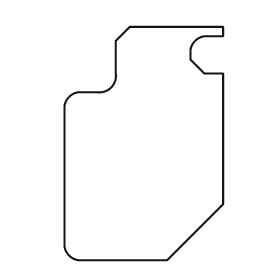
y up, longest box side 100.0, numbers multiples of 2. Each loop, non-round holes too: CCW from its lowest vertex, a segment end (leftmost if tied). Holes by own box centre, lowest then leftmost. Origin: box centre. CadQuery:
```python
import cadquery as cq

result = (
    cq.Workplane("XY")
    .moveTo(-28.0, -50.0)
    .lineTo(10.0, -50.0)
    .lineTo(34.0, -26.0)
    .lineTo(34.0, 30.0)
    .lineTo(26.0, 30.0)
    .lineTo(20.0, 36.0)
    .lineTo(20.0, 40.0)
    .threePointArc((22.0, 44.0), (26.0, 46.0))
    .lineTo(34.0, 46.0)
    .lineTo(34.0, 50.0)
    .lineTo(-6.0, 50.0)
    .lineTo(-12.0, 44.0)
    .lineTo(-12.0, 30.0)
    .threePointArc((-14.0, 24.0), (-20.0, 22.0))
    .lineTo(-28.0, 22.0)
    .threePointArc((-32.0, 20.0), (-34.0, 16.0))
    .lineTo(-34.0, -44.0)
    .threePointArc((-32.0, -48.0), (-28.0, -50.0))
    .close()
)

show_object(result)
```